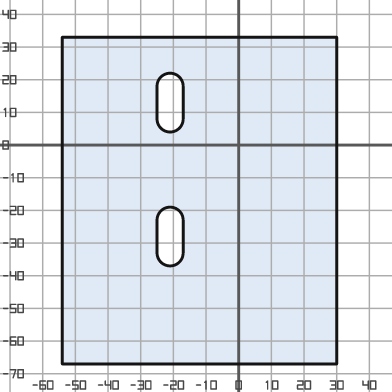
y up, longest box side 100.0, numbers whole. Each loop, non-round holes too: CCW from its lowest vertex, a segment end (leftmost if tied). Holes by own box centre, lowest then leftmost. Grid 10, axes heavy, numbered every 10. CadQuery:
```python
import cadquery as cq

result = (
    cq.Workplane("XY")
    .moveTo(-54.0, -67.0)
    .lineTo(30.0, -67.0)
    .lineTo(30.0, 33.0)
    .lineTo(-54.0, 33.0)
    .close()
    .moveTo(-25.0, -33.0)
    .threePointArc((-21.0, -37.0), (-17.0, -33.0))
    .lineTo(-17.0, -23.0)
    .threePointArc((-21.0, -19.0), (-25.0, -23.0))
    .close()
    .moveTo(-25.0, 8.0)
    .threePointArc((-21.0, 4.0), (-17.0, 8.0))
    .lineTo(-17.0, 18.0)
    .threePointArc((-21.0, 22.0), (-25.0, 18.0))
    .close()
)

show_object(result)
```